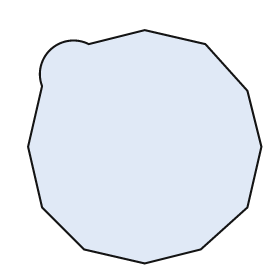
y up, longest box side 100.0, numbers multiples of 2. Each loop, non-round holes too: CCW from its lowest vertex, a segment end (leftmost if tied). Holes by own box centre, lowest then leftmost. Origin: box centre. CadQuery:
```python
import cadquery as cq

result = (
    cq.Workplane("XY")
    .moveTo(0.0, -50.0)
    .lineTo(24.0, -44.0)
    .lineTo(44.0, -26.0)
    .lineTo(50.0, 0.0)
    .lineTo(44.0, 24.0)
    .lineTo(26.0, 44.0)
    .lineTo(0.0, 50.0)
    .lineTo(-24.0, 44.0)
    .threePointArc((-40.0, 42.0), (-44.0, 26.0))
    .lineTo(-50.0, 0.0)
    .lineTo(-44.0, -26.0)
    .lineTo(-26.0, -44.0)
    .close()
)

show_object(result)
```